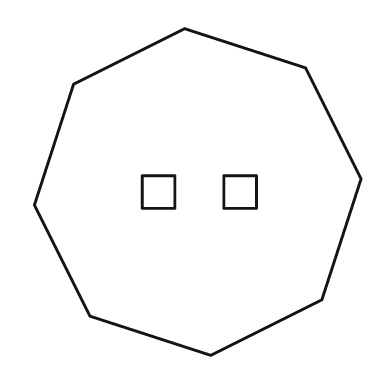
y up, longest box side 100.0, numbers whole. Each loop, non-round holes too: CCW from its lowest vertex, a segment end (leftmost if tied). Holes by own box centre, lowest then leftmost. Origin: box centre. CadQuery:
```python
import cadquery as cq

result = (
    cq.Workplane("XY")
    .moveTo(4.0, -50.0)
    .lineTo(38.0, -33.0)
    .lineTo(50.0, 4.0)
    .lineTo(33.0, 38.0)
    .lineTo(-4.0, 50.0)
    .lineTo(-38.0, 33.0)
    .lineTo(-50.0, -4.0)
    .lineTo(-33.0, -38.0)
    .close()
    .moveTo(-17.0, -5.0)
    .lineTo(-7.0, -5.0)
    .lineTo(-7.0, 5.0)
    .lineTo(-17.0, 5.0)
    .close()
    .moveTo(8.0, -5.0)
    .lineTo(18.0, -5.0)
    .lineTo(18.0, 5.0)
    .lineTo(8.0, 5.0)
    .close()
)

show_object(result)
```